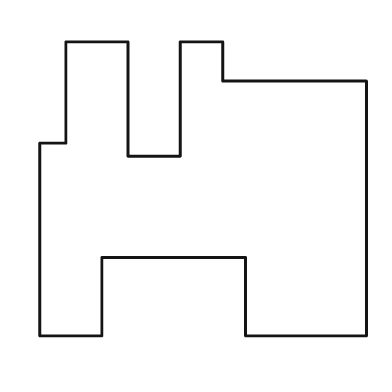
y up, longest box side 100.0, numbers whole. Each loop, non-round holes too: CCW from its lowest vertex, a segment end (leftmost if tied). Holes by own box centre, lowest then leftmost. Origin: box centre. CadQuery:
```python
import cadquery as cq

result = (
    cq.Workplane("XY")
    .moveTo(-50.0, -45.0)
    .lineTo(-31.0, -45.0)
    .lineTo(-31.0, -21.0)
    .lineTo(13.0, -21.0)
    .lineTo(13.0, -45.0)
    .lineTo(50.0, -45.0)
    .lineTo(50.0, 33.0)
    .lineTo(6.0, 33.0)
    .lineTo(6.0, 45.0)
    .lineTo(-7.0, 45.0)
    .lineTo(-7.0, 10.0)
    .lineTo(-23.0, 10.0)
    .lineTo(-23.0, 45.0)
    .lineTo(-42.0, 45.0)
    .lineTo(-42.0, 14.0)
    .lineTo(-50.0, 14.0)
    .close()
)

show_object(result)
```